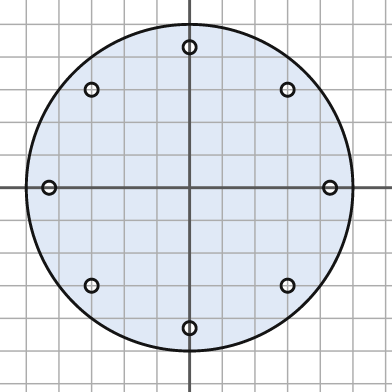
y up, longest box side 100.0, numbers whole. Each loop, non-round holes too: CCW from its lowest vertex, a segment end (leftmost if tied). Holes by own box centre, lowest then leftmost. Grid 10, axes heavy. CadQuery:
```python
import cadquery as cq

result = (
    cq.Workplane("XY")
    .moveTo(0.0, 0.0)
    .circle(50.0)
    .moveTo(0.0, -43.0)
    .circle(2.0)
    .moveTo(-30.0, -30.0)
    .circle(2.0)
    .moveTo(30.0, -30.0)
    .circle(2.0)
    .moveTo(-43.0, 0.0)
    .circle(2.0)
    .moveTo(43.0, 0.0)
    .circle(2.0)
    .moveTo(-30.0, 30.0)
    .circle(2.0)
    .moveTo(30.0, 30.0)
    .circle(2.0)
    .moveTo(0.0, 43.0)
    .circle(2.0)
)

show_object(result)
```